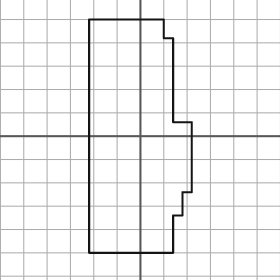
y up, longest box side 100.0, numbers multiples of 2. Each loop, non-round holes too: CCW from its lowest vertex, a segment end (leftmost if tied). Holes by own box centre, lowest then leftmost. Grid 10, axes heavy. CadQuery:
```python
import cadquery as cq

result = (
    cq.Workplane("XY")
    .moveTo(-22.0, -50.0)
    .lineTo(14.0, -50.0)
    .lineTo(14.0, -34.0)
    .lineTo(18.0, -34.0)
    .lineTo(18.0, -24.0)
    .lineTo(22.0, -24.0)
    .lineTo(22.0, 6.0)
    .lineTo(14.0, 6.0)
    .lineTo(14.0, 42.0)
    .lineTo(10.0, 42.0)
    .lineTo(10.0, 50.0)
    .lineTo(-22.0, 50.0)
    .close()
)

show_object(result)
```